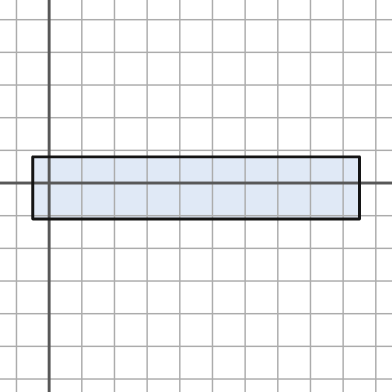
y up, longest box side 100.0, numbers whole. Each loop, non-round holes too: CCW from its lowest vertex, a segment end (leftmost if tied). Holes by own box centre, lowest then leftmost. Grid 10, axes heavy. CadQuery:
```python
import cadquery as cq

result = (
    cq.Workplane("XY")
    .moveTo(-5.0, -11.0)
    .lineTo(95.0, -11.0)
    .lineTo(95.0, 8.0)
    .lineTo(-5.0, 8.0)
    .close()
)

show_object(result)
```